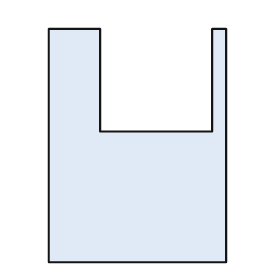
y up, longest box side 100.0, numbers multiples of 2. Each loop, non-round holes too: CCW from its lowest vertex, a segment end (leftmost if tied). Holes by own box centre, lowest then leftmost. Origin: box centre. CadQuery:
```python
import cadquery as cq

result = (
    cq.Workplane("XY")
    .moveTo(-38.0, -50.0)
    .lineTo(38.0, -50.0)
    .lineTo(38.0, 50.0)
    .lineTo(32.0, 50.0)
    .lineTo(32.0, 6.0)
    .lineTo(-16.0, 6.0)
    .lineTo(-16.0, 50.0)
    .lineTo(-38.0, 50.0)
    .close()
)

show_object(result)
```